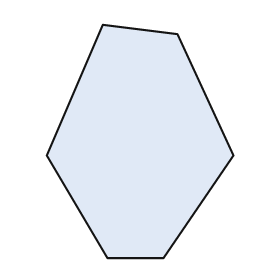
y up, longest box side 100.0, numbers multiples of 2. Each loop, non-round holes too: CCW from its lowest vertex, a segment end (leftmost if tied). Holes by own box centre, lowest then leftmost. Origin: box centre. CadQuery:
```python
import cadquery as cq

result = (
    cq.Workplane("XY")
    .moveTo(-14.0, -50.0)
    .lineTo(10.0, -50.0)
    .lineTo(40.0, -6.0)
    .lineTo(16.0, 46.0)
    .lineTo(-16.0, 50.0)
    .lineTo(-40.0, -6.0)
    .close()
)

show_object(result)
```